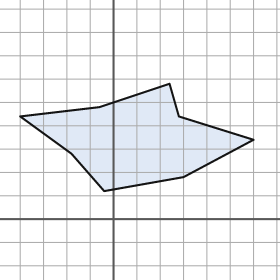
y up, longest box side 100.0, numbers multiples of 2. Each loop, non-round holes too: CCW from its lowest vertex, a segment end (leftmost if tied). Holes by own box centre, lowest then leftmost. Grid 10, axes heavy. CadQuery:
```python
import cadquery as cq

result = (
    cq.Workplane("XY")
    .moveTo(-4.0, 12.0)
    .lineTo(30.0, 18.0)
    .lineTo(60.0, 34.0)
    .lineTo(28.0, 44.0)
    .lineTo(24.0, 58.0)
    .lineTo(-6.0, 48.0)
    .lineTo(-40.0, 44.0)
    .lineTo(-18.0, 28.0)
    .close()
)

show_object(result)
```